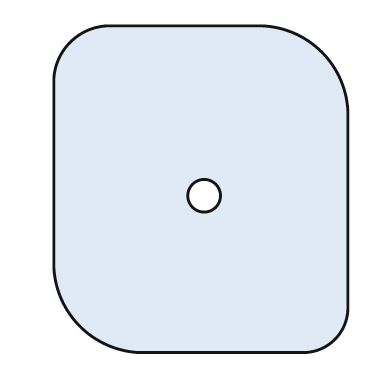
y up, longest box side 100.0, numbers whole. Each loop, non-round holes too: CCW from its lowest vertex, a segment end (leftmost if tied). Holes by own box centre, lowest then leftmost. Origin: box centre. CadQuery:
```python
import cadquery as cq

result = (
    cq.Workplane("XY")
    .moveTo(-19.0, -50.0)
    .lineTo(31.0, -50.0)
    .threePointArc((41.0, -46.0), (45.0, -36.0))
    .lineTo(45.0, 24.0)
    .threePointArc((37.0, 42.0), (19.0, 50.0))
    .lineTo(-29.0, 50.0)
    .threePointArc((-40.0, 45.0), (-45.0, 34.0))
    .lineTo(-45.0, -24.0)
    .threePointArc((-37.0, -42.0), (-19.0, -50.0))
    .close()
    .moveTo(1.0, -2.0)
    .circle(5.0)
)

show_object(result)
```